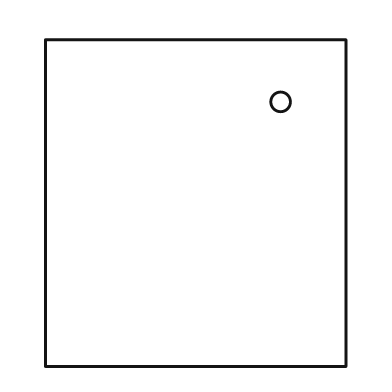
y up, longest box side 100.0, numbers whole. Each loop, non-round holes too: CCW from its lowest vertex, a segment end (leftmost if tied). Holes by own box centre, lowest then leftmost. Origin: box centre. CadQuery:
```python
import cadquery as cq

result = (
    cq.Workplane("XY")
    .moveTo(-46.0, -50.0)
    .lineTo(46.0, -50.0)
    .lineTo(46.0, 50.0)
    .lineTo(-46.0, 50.0)
    .close()
    .moveTo(26.0, 31.0)
    .circle(3.0)
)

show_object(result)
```